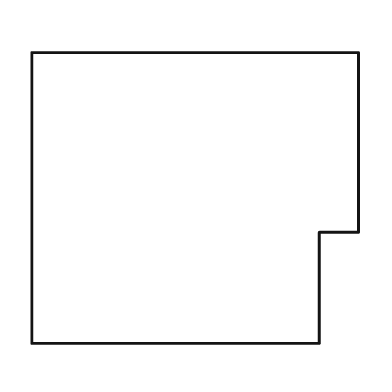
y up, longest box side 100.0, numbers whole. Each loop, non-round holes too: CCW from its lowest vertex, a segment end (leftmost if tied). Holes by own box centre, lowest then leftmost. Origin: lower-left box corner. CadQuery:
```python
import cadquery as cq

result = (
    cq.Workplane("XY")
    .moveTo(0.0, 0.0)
    .lineTo(88.0, 0.0)
    .lineTo(88.0, 34.0)
    .lineTo(100.0, 34.0)
    .lineTo(100.0, 89.0)
    .lineTo(0.0, 89.0)
    .close()
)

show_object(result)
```